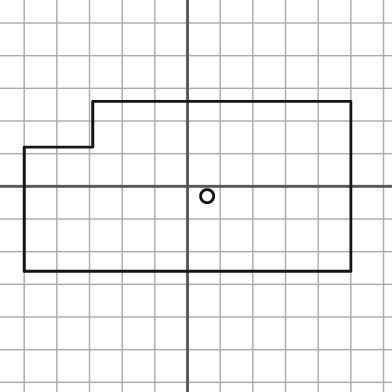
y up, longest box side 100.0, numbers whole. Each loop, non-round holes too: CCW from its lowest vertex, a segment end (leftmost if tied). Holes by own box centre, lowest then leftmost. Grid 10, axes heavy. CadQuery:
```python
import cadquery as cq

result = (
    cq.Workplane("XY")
    .moveTo(-50.0, -26.0)
    .lineTo(50.0, -26.0)
    .lineTo(50.0, 26.0)
    .lineTo(-29.0, 26.0)
    .lineTo(-29.0, 12.0)
    .lineTo(-50.0, 12.0)
    .close()
    .moveTo(6.0, -3.0)
    .circle(2.0)
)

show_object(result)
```